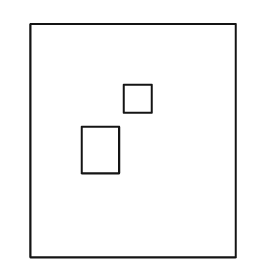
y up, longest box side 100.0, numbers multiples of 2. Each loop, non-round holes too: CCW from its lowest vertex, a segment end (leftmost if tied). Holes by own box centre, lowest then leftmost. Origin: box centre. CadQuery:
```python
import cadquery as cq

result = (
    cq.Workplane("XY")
    .moveTo(-44.0, -50.0)
    .lineTo(44.0, -50.0)
    .lineTo(44.0, 50.0)
    .lineTo(-44.0, 50.0)
    .close()
    .moveTo(-22.0, -14.0)
    .lineTo(-6.0, -14.0)
    .lineTo(-6.0, 6.0)
    .lineTo(-22.0, 6.0)
    .close()
    .moveTo(-4.0, 12.0)
    .lineTo(8.0, 12.0)
    .lineTo(8.0, 24.0)
    .lineTo(-4.0, 24.0)
    .close()
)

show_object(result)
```